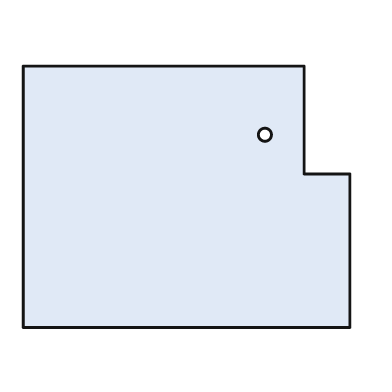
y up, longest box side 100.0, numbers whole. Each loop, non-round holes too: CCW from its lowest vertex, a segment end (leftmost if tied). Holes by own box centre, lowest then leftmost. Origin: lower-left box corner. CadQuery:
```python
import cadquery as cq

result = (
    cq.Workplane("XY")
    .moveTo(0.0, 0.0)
    .lineTo(100.0, 0.0)
    .lineTo(100.0, 47.0)
    .lineTo(86.0, 47.0)
    .lineTo(86.0, 80.0)
    .lineTo(0.0, 80.0)
    .close()
    .moveTo(74.0, 59.0)
    .circle(2.0)
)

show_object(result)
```